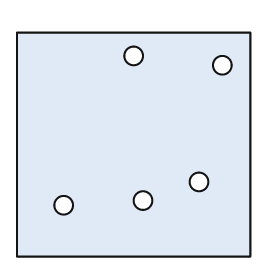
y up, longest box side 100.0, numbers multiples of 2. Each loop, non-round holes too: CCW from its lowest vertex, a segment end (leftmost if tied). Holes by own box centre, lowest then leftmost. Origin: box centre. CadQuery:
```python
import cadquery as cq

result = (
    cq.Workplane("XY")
    .moveTo(-50.0, -48.0)
    .lineTo(50.0, -48.0)
    .lineTo(50.0, 48.0)
    .lineTo(-50.0, 48.0)
    .close()
    .moveTo(-30.0, -26.0)
    .circle(4.0)
    .moveTo(4.0, -24.0)
    .circle(4.0)
    .moveTo(28.0, -16.0)
    .circle(4.0)
    .moveTo(38.0, 34.0)
    .circle(4.0)
    .moveTo(0.0, 38.0)
    .circle(4.0)
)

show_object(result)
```